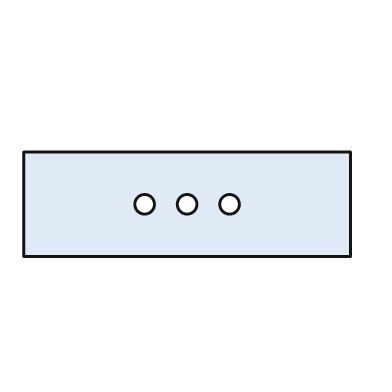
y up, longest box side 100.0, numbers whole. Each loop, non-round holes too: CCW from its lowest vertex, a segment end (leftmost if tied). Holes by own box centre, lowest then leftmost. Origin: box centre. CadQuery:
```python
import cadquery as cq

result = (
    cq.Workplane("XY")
    .moveTo(-50.0, -16.0)
    .lineTo(50.0, -16.0)
    .lineTo(50.0, 16.0)
    .lineTo(-50.0, 16.0)
    .close()
    .moveTo(-13.0, 0.0)
    .circle(3.0)
    .moveTo(0.0, 0.0)
    .circle(3.0)
    .moveTo(13.0, 0.0)
    .circle(3.0)
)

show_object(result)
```